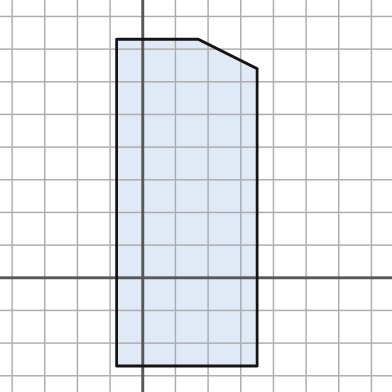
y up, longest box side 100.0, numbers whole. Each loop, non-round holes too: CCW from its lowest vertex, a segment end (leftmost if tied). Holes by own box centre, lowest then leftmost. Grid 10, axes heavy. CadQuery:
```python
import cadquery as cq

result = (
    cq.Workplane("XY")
    .moveTo(-8.0, -27.0)
    .lineTo(35.0, -27.0)
    .lineTo(35.0, 64.0)
    .lineTo(17.0, 73.0)
    .lineTo(-8.0, 73.0)
    .close()
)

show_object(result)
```